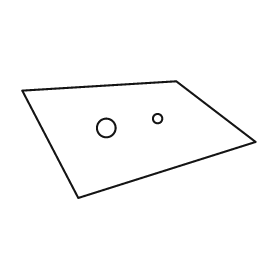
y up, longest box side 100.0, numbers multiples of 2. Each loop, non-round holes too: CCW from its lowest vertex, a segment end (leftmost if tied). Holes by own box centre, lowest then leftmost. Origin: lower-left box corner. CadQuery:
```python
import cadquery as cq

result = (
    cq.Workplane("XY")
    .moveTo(24.0, 0.0)
    .lineTo(100.0, 24.0)
    .lineTo(66.0, 50.0)
    .lineTo(0.0, 46.0)
    .close()
    .moveTo(36.0, 30.0)
    .circle(4.0)
    .moveTo(58.0, 34.0)
    .circle(2.0)
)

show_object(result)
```